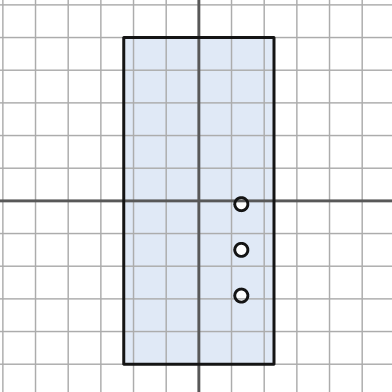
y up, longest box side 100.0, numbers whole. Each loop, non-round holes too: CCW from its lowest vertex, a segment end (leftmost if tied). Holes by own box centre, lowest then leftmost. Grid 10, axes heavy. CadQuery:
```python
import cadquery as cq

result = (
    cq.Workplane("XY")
    .moveTo(-23.0, -50.0)
    .lineTo(23.0, -50.0)
    .lineTo(23.0, 50.0)
    .lineTo(-23.0, 50.0)
    .close()
    .moveTo(13.0, -29.0)
    .circle(2.0)
    .moveTo(13.0, -15.0)
    .circle(2.0)
    .moveTo(13.0, -1.0)
    .circle(2.0)
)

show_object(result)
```